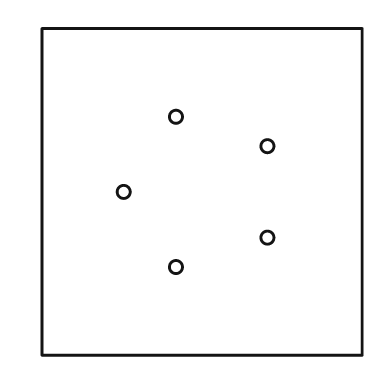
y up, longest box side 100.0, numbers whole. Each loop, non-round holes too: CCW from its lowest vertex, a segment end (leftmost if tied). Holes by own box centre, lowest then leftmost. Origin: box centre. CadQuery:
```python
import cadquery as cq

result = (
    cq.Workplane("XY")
    .moveTo(-49.0, -50.0)
    .lineTo(49.0, -50.0)
    .lineTo(49.0, 50.0)
    .lineTo(-49.0, 50.0)
    .close()
    .moveTo(-8.0, -23.0)
    .circle(2.0)
    .moveTo(20.0, -14.0)
    .circle(2.0)
    .moveTo(-24.0, 0.0)
    .circle(2.0)
    .moveTo(20.0, 14.0)
    .circle(2.0)
    .moveTo(-8.0, 23.0)
    .circle(2.0)
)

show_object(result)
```